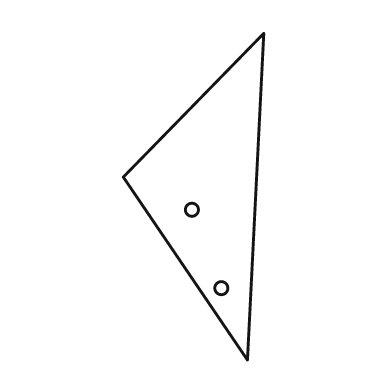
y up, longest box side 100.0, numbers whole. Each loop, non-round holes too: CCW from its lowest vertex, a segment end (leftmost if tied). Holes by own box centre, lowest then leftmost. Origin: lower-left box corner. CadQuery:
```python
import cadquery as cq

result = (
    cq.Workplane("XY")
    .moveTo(38.0, 0.0)
    .lineTo(43.0, 100.0)
    .lineTo(0.0, 56.0)
    .close()
    .moveTo(30.0, 22.0)
    .circle(2.0)
    .moveTo(21.0, 46.0)
    .circle(2.0)
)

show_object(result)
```